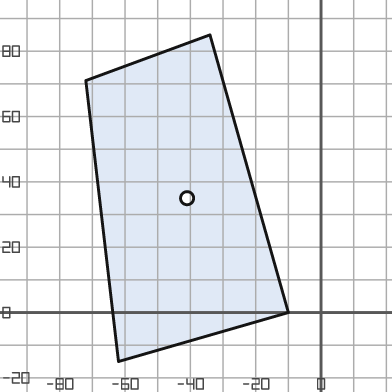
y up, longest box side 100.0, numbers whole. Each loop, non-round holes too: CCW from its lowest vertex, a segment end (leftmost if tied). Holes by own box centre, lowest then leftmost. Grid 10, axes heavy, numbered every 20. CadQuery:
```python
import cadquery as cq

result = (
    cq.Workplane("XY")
    .moveTo(-62.0, -15.0)
    .lineTo(-10.0, 0.0)
    .lineTo(-34.0, 85.0)
    .lineTo(-72.0, 71.0)
    .close()
    .moveTo(-41.0, 35.0)
    .circle(2.0)
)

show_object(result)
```